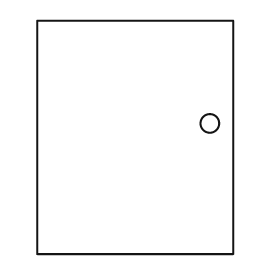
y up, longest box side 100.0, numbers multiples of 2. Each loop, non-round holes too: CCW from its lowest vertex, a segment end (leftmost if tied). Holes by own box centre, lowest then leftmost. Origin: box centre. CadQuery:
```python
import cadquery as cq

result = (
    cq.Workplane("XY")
    .moveTo(-42.0, -50.0)
    .lineTo(42.0, -50.0)
    .lineTo(42.0, 50.0)
    .lineTo(-42.0, 50.0)
    .close()
    .moveTo(32.0, 6.0)
    .circle(4.0)
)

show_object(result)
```